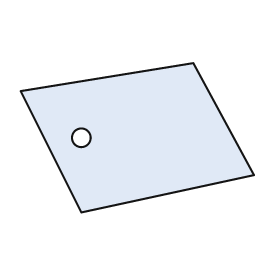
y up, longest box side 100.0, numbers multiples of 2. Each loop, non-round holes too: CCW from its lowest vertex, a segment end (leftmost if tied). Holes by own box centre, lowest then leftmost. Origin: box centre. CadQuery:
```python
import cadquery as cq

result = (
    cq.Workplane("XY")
    .moveTo(-24.0, -32.0)
    .lineTo(50.0, -16.0)
    .lineTo(24.0, 32.0)
    .lineTo(-50.0, 20.0)
    .close()
    .moveTo(-24.0, 0.0)
    .circle(4.0)
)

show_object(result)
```